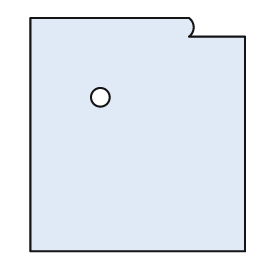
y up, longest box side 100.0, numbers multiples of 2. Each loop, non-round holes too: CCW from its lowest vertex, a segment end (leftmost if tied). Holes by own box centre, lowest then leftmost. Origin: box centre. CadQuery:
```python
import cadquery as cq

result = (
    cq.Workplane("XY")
    .moveTo(-46.0, -50.0)
    .lineTo(46.0, -50.0)
    .lineTo(46.0, 42.0)
    .lineTo(22.0, 42.0)
    .threePointArc((24.0, 46.0), (22.0, 50.0))
    .lineTo(-46.0, 50.0)
    .close()
    .moveTo(-16.0, 16.0)
    .circle(4.0)
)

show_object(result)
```